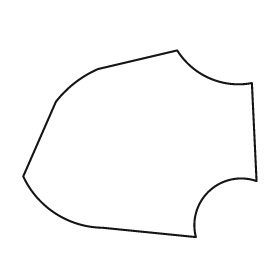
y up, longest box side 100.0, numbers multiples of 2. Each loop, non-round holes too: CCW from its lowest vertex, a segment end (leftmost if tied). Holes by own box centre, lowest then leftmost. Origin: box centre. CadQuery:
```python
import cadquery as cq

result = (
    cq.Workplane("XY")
    .moveTo(24.0, -40.0)
    .threePointArc((30.0, -20.0), (50.0, -16.0))
    .lineTo(48.0, 26.0)
    .threePointArc((30.0, 28.0), (16.0, 40.0))
    .lineTo(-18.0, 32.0)
    .threePointArc((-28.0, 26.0), (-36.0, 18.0))
    .lineTo(-50.0, -14.0)
    .threePointArc((-36.0, -30.0), (-16.0, -36.0))
    .close()
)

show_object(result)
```